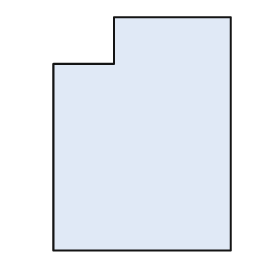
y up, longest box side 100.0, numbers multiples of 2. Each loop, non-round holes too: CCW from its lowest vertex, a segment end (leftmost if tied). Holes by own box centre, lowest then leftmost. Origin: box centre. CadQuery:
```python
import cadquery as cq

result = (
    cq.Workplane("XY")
    .moveTo(-38.0, -50.0)
    .lineTo(38.0, -50.0)
    .lineTo(38.0, 50.0)
    .lineTo(-12.0, 50.0)
    .lineTo(-12.0, 30.0)
    .lineTo(-38.0, 30.0)
    .close()
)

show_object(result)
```